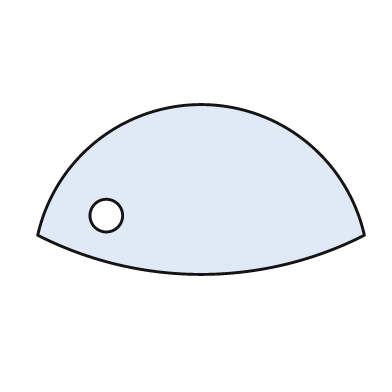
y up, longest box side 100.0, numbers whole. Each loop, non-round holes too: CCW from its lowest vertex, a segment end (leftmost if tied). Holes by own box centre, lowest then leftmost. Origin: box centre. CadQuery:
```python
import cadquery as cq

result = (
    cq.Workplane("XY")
    .moveTo(-50.0, -14.0)
    .threePointArc((0.0, -26.0), (50.0, -14.0))
    .threePointArc((0.0, 26.0), (-50.0, -14.0))
    .close()
    .moveTo(-29.0, -8.0)
    .circle(5.0)
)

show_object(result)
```